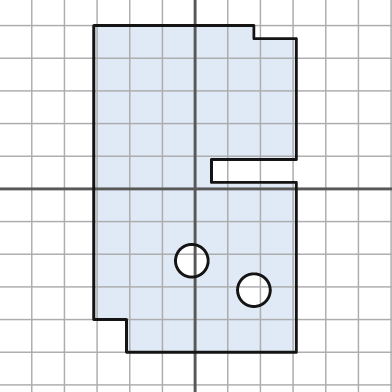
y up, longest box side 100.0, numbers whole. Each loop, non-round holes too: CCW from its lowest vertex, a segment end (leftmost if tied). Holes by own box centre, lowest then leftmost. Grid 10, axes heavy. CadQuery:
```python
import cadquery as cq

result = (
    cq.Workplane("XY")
    .moveTo(-21.0, -50.0)
    .lineTo(31.0, -50.0)
    .lineTo(31.0, 2.0)
    .lineTo(5.0, 2.0)
    .lineTo(5.0, 9.0)
    .lineTo(31.0, 9.0)
    .lineTo(31.0, 46.0)
    .lineTo(18.0, 46.0)
    .lineTo(18.0, 50.0)
    .lineTo(-31.0, 50.0)
    .lineTo(-31.0, -40.0)
    .lineTo(-21.0, -40.0)
    .close()
    .moveTo(18.0, -31.0)
    .circle(5.0)
    .moveTo(-1.0, -22.0)
    .circle(5.0)
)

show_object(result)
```